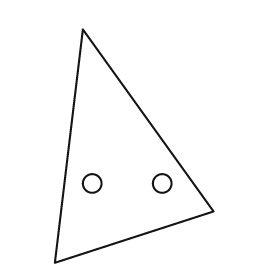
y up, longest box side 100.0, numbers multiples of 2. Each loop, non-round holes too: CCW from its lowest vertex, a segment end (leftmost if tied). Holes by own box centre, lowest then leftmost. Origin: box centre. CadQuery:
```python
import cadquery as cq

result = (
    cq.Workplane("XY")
    .moveTo(-34.0, -50.0)
    .lineTo(34.0, -28.0)
    .lineTo(-22.0, 50.0)
    .close()
    .moveTo(-18.0, -16.0)
    .circle(4.0)
    .moveTo(12.0, -16.0)
    .circle(4.0)
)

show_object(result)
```